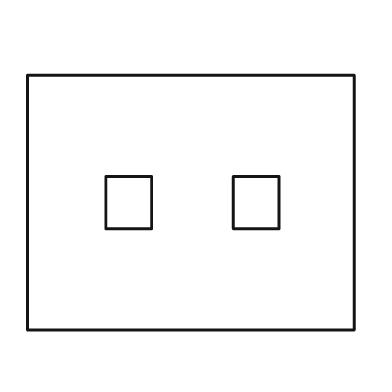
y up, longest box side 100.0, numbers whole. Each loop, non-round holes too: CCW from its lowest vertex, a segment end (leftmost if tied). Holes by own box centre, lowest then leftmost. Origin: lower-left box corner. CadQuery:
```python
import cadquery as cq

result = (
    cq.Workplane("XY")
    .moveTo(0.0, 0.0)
    .lineTo(100.0, 0.0)
    .lineTo(100.0, 78.0)
    .lineTo(0.0, 78.0)
    .close()
    .moveTo(24.0, 31.0)
    .lineTo(38.0, 31.0)
    .lineTo(38.0, 47.0)
    .lineTo(24.0, 47.0)
    .close()
    .moveTo(63.0, 31.0)
    .lineTo(77.0, 31.0)
    .lineTo(77.0, 47.0)
    .lineTo(63.0, 47.0)
    .close()
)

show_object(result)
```